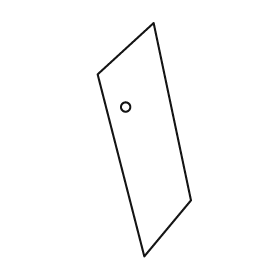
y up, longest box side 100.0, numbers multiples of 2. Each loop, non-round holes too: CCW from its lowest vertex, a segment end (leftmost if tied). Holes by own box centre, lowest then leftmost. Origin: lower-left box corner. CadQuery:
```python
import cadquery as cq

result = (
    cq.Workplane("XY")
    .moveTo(20.0, 0.0)
    .lineTo(40.0, 24.0)
    .lineTo(24.0, 100.0)
    .lineTo(0.0, 78.0)
    .close()
    .moveTo(12.0, 64.0)
    .circle(2.0)
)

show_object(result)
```